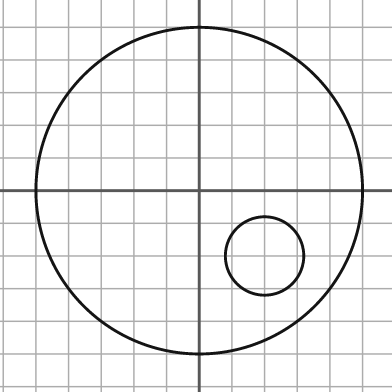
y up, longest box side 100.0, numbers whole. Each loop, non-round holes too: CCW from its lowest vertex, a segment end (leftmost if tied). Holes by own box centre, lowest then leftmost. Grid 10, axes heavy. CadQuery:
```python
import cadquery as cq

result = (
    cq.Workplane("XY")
    .moveTo(0.0, 0.0)
    .circle(50.0)
    .moveTo(20.0, -20.0)
    .circle(12.0)
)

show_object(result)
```